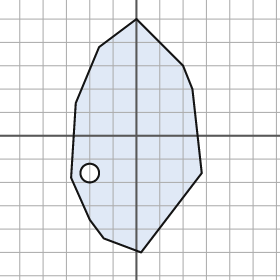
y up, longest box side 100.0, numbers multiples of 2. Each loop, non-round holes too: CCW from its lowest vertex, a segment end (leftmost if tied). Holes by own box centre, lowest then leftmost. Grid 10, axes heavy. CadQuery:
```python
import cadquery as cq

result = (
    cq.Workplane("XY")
    .moveTo(2.0, -50.0)
    .lineTo(28.0, -16.0)
    .lineTo(24.0, 20.0)
    .lineTo(20.0, 30.0)
    .lineTo(0.0, 50.0)
    .lineTo(-16.0, 38.0)
    .lineTo(-26.0, 14.0)
    .lineTo(-28.0, -18.0)
    .lineTo(-20.0, -36.0)
    .lineTo(-14.0, -44.0)
    .close()
    .moveTo(-20.0, -16.0)
    .circle(4.0)
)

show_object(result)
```